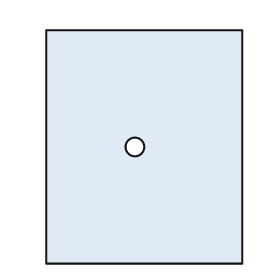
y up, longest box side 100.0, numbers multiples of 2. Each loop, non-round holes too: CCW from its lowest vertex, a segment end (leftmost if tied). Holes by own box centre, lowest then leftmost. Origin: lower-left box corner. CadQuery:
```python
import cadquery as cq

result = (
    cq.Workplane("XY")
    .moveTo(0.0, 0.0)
    .lineTo(84.0, 0.0)
    .lineTo(84.0, 100.0)
    .lineTo(0.0, 100.0)
    .close()
    .moveTo(38.0, 50.0)
    .circle(4.0)
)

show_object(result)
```